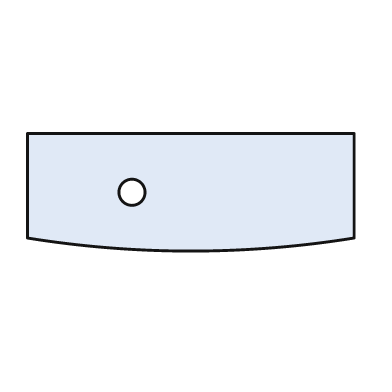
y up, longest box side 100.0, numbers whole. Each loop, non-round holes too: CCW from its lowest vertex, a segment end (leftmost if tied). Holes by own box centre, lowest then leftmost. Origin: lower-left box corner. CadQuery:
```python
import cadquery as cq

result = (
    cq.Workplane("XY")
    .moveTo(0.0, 4.0)
    .threePointArc((50.0, 0.0), (100.0, 4.0))
    .lineTo(100.0, 36.0)
    .lineTo(0.0, 36.0)
    .close()
    .moveTo(32.0, 18.0)
    .circle(4.0)
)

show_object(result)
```